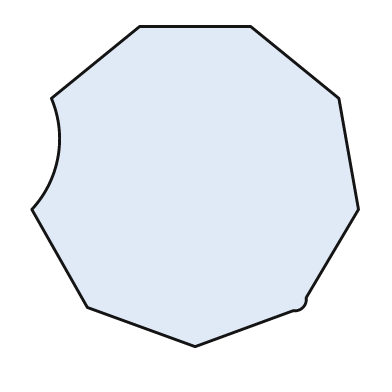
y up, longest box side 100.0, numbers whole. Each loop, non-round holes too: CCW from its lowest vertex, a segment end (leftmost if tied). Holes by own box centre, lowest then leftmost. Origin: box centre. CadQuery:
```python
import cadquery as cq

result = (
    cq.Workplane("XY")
    .moveTo(0.0, -49.0)
    .lineTo(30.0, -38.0)
    .threePointArc((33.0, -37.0), (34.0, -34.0))
    .lineTo(50.0, -7.0)
    .lineTo(44.0, 27.0)
    .lineTo(17.0, 49.0)
    .lineTo(-17.0, 49.0)
    .lineTo(-44.0, 27.0)
    .threePointArc((-42.0, 9.0), (-50.0, -7.0))
    .lineTo(-33.0, -37.0)
    .close()
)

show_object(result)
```